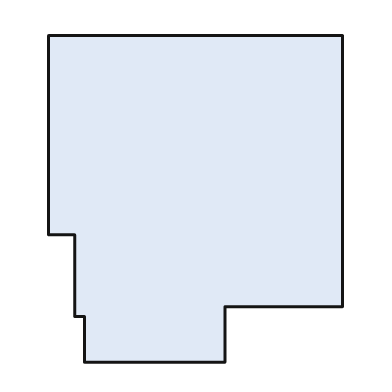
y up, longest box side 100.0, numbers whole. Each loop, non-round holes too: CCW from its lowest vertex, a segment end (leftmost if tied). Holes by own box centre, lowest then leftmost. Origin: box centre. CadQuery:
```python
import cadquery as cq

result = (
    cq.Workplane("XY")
    .moveTo(-34.0, -50.0)
    .lineTo(9.0, -50.0)
    .lineTo(9.0, -33.0)
    .lineTo(45.0, -33.0)
    .lineTo(45.0, 50.0)
    .lineTo(-45.0, 50.0)
    .lineTo(-45.0, -11.0)
    .lineTo(-37.0, -11.0)
    .lineTo(-37.0, -36.0)
    .lineTo(-34.0, -36.0)
    .close()
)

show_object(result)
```